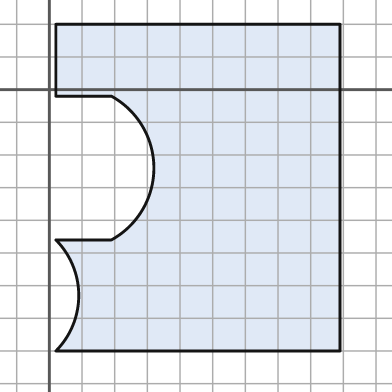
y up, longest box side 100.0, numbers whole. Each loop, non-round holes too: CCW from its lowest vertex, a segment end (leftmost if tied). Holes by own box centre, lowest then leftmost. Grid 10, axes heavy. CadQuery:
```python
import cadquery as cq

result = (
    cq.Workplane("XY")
    .moveTo(2.0, -80.0)
    .lineTo(89.0, -80.0)
    .lineTo(89.0, 20.0)
    .lineTo(2.0, 20.0)
    .lineTo(2.0, -2.0)
    .lineTo(19.0, -2.0)
    .threePointArc((32.0, -24.0), (19.0, -46.0))
    .lineTo(2.0, -46.0)
    .threePointArc((9.0, -63.0), (2.0, -80.0))
    .close()
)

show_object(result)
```